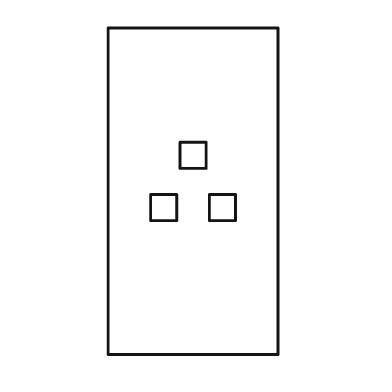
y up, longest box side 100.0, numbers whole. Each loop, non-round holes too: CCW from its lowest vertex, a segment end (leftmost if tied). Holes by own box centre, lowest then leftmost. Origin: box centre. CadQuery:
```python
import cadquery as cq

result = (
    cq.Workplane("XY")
    .moveTo(-26.0, -50.0)
    .lineTo(26.0, -50.0)
    .lineTo(26.0, 50.0)
    .lineTo(-26.0, 50.0)
    .close()
    .moveTo(-13.0, -9.0)
    .lineTo(-5.0, -9.0)
    .lineTo(-5.0, -1.0)
    .lineTo(-13.0, -1.0)
    .close()
    .moveTo(5.0, -9.0)
    .lineTo(13.0, -9.0)
    .lineTo(13.0, -1.0)
    .lineTo(5.0, -1.0)
    .close()
    .moveTo(-4.0, 7.0)
    .lineTo(4.0, 7.0)
    .lineTo(4.0, 15.0)
    .lineTo(-4.0, 15.0)
    .close()
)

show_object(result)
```